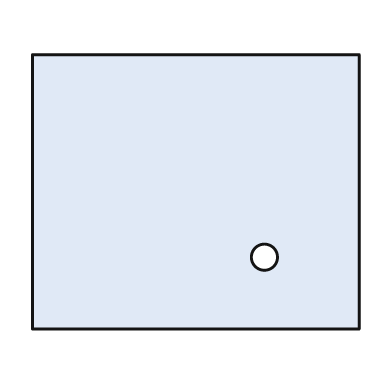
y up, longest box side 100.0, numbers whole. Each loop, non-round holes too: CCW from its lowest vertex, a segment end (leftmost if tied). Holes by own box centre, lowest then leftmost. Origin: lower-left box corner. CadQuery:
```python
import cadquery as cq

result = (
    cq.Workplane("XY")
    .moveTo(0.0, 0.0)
    .lineTo(100.0, 0.0)
    .lineTo(100.0, 84.0)
    .lineTo(0.0, 84.0)
    .close()
    .moveTo(71.0, 22.0)
    .circle(4.0)
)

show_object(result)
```